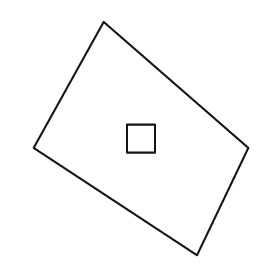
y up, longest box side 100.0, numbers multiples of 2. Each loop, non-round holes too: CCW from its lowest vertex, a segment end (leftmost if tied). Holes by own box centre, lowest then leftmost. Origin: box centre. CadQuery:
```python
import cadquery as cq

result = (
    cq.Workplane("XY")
    .moveTo(24.0, -50.0)
    .lineTo(46.0, -4.0)
    .lineTo(-16.0, 50.0)
    .lineTo(-46.0, -4.0)
    .close()
    .moveTo(-6.0, -6.0)
    .lineTo(6.0, -6.0)
    .lineTo(6.0, 6.0)
    .lineTo(-6.0, 6.0)
    .close()
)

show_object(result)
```